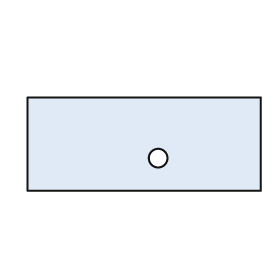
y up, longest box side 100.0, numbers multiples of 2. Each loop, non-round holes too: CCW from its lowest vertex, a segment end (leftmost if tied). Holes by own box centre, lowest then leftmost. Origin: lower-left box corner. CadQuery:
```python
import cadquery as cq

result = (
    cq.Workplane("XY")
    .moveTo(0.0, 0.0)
    .lineTo(100.0, 0.0)
    .lineTo(100.0, 40.0)
    .lineTo(0.0, 40.0)
    .close()
    .moveTo(56.0, 14.0)
    .circle(4.0)
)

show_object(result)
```